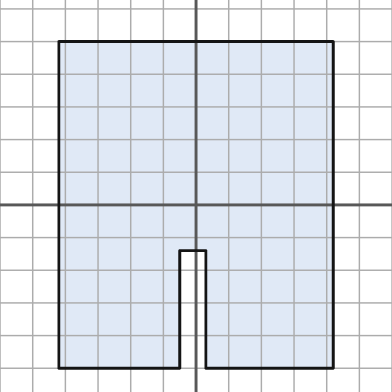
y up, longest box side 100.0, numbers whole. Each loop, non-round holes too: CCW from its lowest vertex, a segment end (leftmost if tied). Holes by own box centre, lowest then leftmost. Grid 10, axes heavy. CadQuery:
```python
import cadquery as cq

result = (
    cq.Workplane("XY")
    .moveTo(-42.0, -50.0)
    .lineTo(-5.0, -50.0)
    .lineTo(-5.0, -14.0)
    .lineTo(3.0, -14.0)
    .lineTo(3.0, -50.0)
    .lineTo(42.0, -50.0)
    .lineTo(42.0, 50.0)
    .lineTo(-42.0, 50.0)
    .close()
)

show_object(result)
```